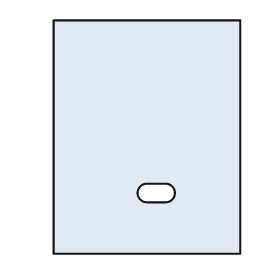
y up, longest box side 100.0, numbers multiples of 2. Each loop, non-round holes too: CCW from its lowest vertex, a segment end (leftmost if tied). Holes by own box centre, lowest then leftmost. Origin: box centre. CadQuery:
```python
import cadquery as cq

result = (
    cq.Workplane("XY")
    .moveTo(-40.0, -50.0)
    .lineTo(40.0, -50.0)
    .lineTo(40.0, 50.0)
    .lineTo(-40.0, 50.0)
    .close()
    .moveTo(0.0, -28.0)
    .lineTo(8.0, -28.0)
    .threePointArc((12.0, -24.0), (8.0, -20.0))
    .lineTo(0.0, -20.0)
    .threePointArc((-4.0, -24.0), (0.0, -28.0))
    .close()
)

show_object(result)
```